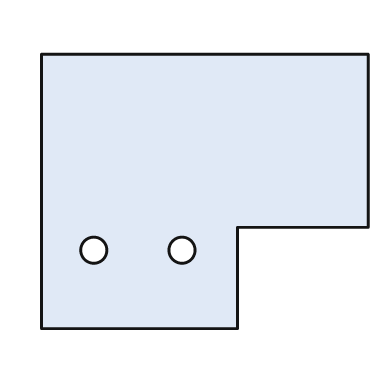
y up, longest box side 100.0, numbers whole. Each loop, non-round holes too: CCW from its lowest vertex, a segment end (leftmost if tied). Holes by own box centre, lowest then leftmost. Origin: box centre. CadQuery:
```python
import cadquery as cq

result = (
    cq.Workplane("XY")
    .moveTo(-50.0, -42.0)
    .lineTo(10.0, -42.0)
    .lineTo(10.0, -11.0)
    .lineTo(50.0, -11.0)
    .lineTo(50.0, 42.0)
    .lineTo(-50.0, 42.0)
    .close()
    .moveTo(-34.0, -18.0)
    .circle(4.0)
    .moveTo(-7.0, -18.0)
    .circle(4.0)
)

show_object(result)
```